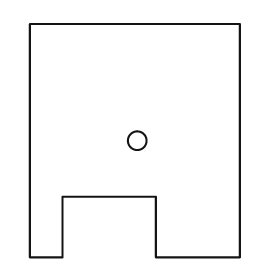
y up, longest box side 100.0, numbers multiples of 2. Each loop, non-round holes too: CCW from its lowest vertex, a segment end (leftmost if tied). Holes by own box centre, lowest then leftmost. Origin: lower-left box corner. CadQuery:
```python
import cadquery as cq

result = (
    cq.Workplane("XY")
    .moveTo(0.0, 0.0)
    .lineTo(14.0, 0.0)
    .lineTo(14.0, 26.0)
    .lineTo(54.0, 26.0)
    .lineTo(54.0, 0.0)
    .lineTo(90.0, 0.0)
    .lineTo(90.0, 100.0)
    .lineTo(0.0, 100.0)
    .close()
    .moveTo(46.0, 50.0)
    .circle(4.0)
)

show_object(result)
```